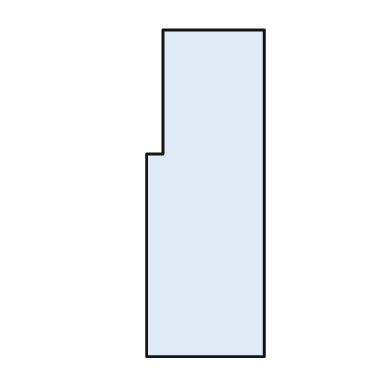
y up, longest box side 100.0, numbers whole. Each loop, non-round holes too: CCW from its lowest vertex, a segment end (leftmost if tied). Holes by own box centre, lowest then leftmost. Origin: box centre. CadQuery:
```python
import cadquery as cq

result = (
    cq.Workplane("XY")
    .moveTo(-18.0, -50.0)
    .lineTo(18.0, -50.0)
    .lineTo(18.0, 50.0)
    .lineTo(-13.0, 50.0)
    .lineTo(-13.0, 12.0)
    .lineTo(-18.0, 12.0)
    .close()
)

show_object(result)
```